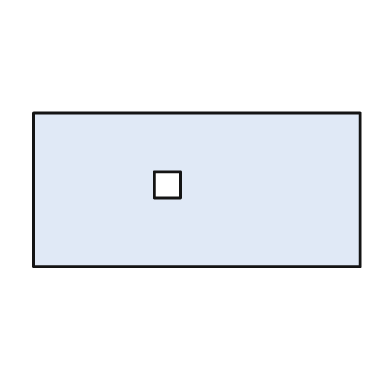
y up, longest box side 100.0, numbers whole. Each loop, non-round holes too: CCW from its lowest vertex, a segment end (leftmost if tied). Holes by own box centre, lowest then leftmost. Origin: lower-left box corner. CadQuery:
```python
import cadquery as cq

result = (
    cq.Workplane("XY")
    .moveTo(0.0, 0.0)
    .lineTo(100.0, 0.0)
    .lineTo(100.0, 47.0)
    .lineTo(0.0, 47.0)
    .close()
    .moveTo(37.0, 21.0)
    .lineTo(45.0, 21.0)
    .lineTo(45.0, 29.0)
    .lineTo(37.0, 29.0)
    .close()
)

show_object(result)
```